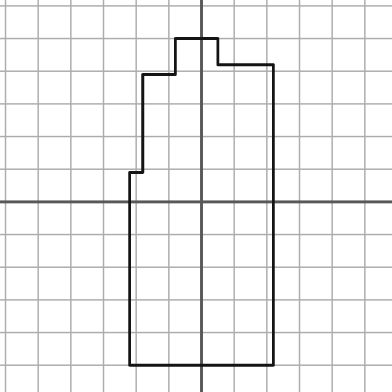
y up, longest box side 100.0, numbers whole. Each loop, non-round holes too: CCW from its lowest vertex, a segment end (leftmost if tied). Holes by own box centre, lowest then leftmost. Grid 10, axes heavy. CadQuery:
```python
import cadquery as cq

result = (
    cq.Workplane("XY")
    .moveTo(-22.0, -50.0)
    .lineTo(22.0, -50.0)
    .lineTo(22.0, 42.0)
    .lineTo(5.0, 42.0)
    .lineTo(5.0, 50.0)
    .lineTo(-8.0, 50.0)
    .lineTo(-8.0, 39.0)
    .lineTo(-18.0, 39.0)
    .lineTo(-18.0, 9.0)
    .lineTo(-22.0, 9.0)
    .close()
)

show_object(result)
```